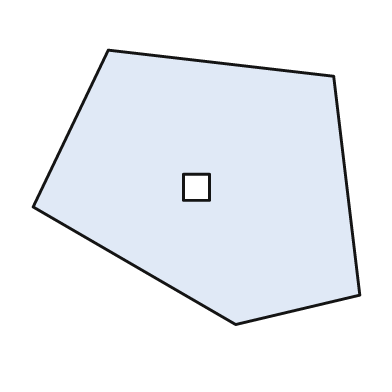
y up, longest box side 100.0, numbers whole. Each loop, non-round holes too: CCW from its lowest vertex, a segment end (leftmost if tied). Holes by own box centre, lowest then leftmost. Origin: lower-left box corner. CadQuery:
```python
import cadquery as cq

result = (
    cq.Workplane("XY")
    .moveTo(62.0, 0.0)
    .lineTo(100.0, 9.0)
    .lineTo(92.0, 76.0)
    .lineTo(23.0, 84.0)
    .lineTo(0.0, 36.0)
    .close()
    .moveTo(46.0, 38.0)
    .lineTo(54.0, 38.0)
    .lineTo(54.0, 46.0)
    .lineTo(46.0, 46.0)
    .close()
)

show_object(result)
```